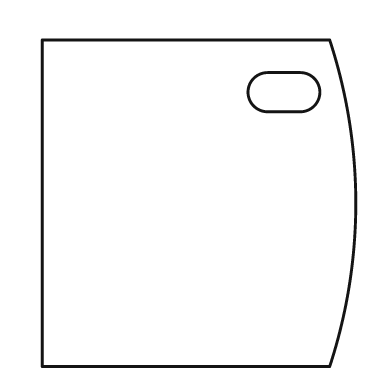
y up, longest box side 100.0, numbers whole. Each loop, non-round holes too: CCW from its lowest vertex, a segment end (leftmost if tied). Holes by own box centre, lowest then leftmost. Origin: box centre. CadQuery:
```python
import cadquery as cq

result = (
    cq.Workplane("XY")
    .moveTo(-48.0, -50.0)
    .lineTo(40.0, -50.0)
    .threePointArc((48.0, 0.0), (40.0, 50.0))
    .lineTo(-48.0, 50.0)
    .close()
    .moveTo(21.0, 28.0)
    .lineTo(31.0, 28.0)
    .threePointArc((37.0, 34.0), (31.0, 40.0))
    .lineTo(21.0, 40.0)
    .threePointArc((15.0, 34.0), (21.0, 28.0))
    .close()
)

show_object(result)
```